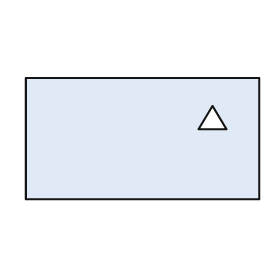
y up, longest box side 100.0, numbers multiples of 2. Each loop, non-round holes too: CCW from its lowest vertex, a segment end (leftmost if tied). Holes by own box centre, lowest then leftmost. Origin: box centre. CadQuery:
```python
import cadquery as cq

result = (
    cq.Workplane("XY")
    .moveTo(-50.0, -26.0)
    .lineTo(50.0, -26.0)
    .lineTo(50.0, 26.0)
    .lineTo(-50.0, 26.0)
    .close()
    .moveTo(24.0, 4.0)
    .lineTo(36.0, 4.0)
    .lineTo(30.0, 14.0)
    .close()
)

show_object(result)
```